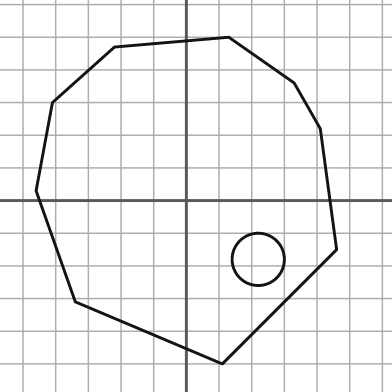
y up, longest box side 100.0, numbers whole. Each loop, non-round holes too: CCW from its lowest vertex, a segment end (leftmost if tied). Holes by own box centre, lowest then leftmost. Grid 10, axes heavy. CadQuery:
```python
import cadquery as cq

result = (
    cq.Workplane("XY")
    .moveTo(11.0, -50.0)
    .lineTo(46.0, -15.0)
    .lineTo(41.0, 22.0)
    .lineTo(33.0, 36.0)
    .lineTo(13.0, 50.0)
    .lineTo(-22.0, 47.0)
    .lineTo(-41.0, 30.0)
    .lineTo(-46.0, 3.0)
    .lineTo(-34.0, -31.0)
    .close()
    .moveTo(22.0, -18.0)
    .circle(8.0)
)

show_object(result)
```